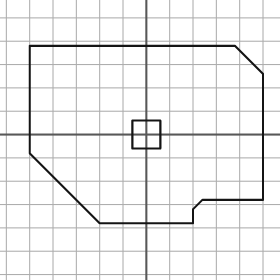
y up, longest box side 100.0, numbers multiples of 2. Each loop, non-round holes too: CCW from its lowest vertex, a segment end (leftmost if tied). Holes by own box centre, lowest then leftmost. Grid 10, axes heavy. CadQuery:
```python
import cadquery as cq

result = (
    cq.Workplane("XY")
    .moveTo(-20.0, -38.0)
    .lineTo(20.0, -38.0)
    .lineTo(20.0, -32.0)
    .lineTo(24.0, -28.0)
    .lineTo(50.0, -28.0)
    .lineTo(50.0, 26.0)
    .lineTo(38.0, 38.0)
    .lineTo(-50.0, 38.0)
    .lineTo(-50.0, -8.0)
    .close()
    .moveTo(-6.0, -6.0)
    .lineTo(6.0, -6.0)
    .lineTo(6.0, 6.0)
    .lineTo(-6.0, 6.0)
    .close()
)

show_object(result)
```